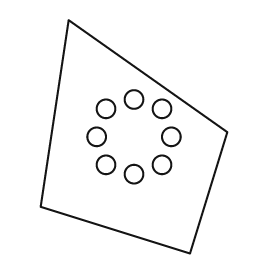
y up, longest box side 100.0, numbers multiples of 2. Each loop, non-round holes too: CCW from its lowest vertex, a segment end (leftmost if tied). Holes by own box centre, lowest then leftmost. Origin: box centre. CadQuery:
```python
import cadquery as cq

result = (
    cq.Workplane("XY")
    .moveTo(24.0, -50.0)
    .lineTo(40.0, 2.0)
    .lineTo(-28.0, 50.0)
    .lineTo(-40.0, -30.0)
    .close()
    .moveTo(0.0, -16.0)
    .circle(4.0)
    .moveTo(-12.0, -12.0)
    .circle(4.0)
    .moveTo(12.0, -12.0)
    .circle(4.0)
    .moveTo(-16.0, 0.0)
    .circle(4.0)
    .moveTo(16.0, 0.0)
    .circle(4.0)
    .moveTo(-12.0, 12.0)
    .circle(4.0)
    .moveTo(12.0, 12.0)
    .circle(4.0)
    .moveTo(0.0, 16.0)
    .circle(4.0)
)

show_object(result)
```